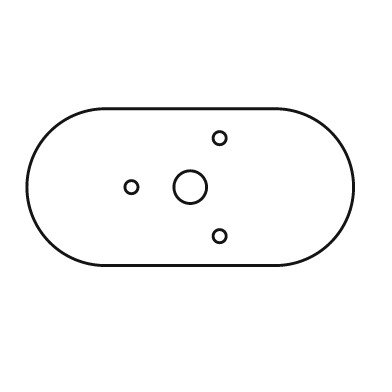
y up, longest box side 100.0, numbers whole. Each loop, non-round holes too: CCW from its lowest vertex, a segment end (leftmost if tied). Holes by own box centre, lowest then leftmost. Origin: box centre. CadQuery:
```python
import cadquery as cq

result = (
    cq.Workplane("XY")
    .moveTo(-26.0, -24.0)
    .lineTo(26.0, -24.0)
    .threePointArc((50.0, 0.0), (26.0, 24.0))
    .lineTo(-26.0, 24.0)
    .threePointArc((-50.0, 0.0), (-26.0, -24.0))
    .close()
    .moveTo(9.0, -15.0)
    .circle(2.0)
    .moveTo(-18.0, 0.0)
    .circle(2.0)
    .moveTo(0.0, 0.0)
    .circle(5.0)
    .moveTo(9.0, 15.0)
    .circle(2.0)
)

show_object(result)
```